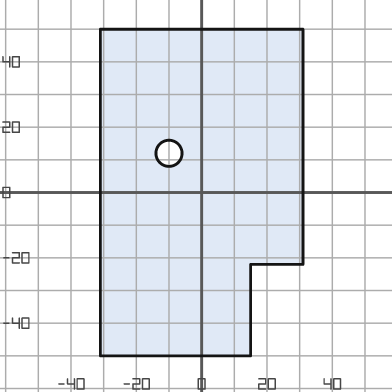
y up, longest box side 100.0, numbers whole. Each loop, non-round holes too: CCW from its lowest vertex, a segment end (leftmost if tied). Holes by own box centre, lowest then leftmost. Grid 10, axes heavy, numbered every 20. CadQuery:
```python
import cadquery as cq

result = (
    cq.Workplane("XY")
    .moveTo(-31.0, -50.0)
    .lineTo(15.0, -50.0)
    .lineTo(15.0, -22.0)
    .lineTo(31.0, -22.0)
    .lineTo(31.0, 50.0)
    .lineTo(-31.0, 50.0)
    .close()
    .moveTo(-10.0, 12.0)
    .circle(4.0)
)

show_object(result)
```